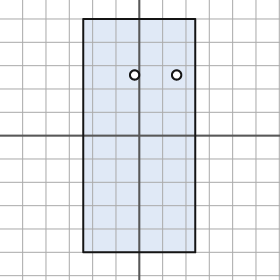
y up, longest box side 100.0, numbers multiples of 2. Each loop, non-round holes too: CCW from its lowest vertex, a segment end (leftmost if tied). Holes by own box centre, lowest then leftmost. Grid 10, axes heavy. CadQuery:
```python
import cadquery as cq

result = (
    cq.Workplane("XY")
    .moveTo(-24.0, -50.0)
    .lineTo(24.0, -50.0)
    .lineTo(24.0, 50.0)
    .lineTo(-24.0, 50.0)
    .close()
    .moveTo(-2.0, 26.0)
    .circle(2.0)
    .moveTo(16.0, 26.0)
    .circle(2.0)
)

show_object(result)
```